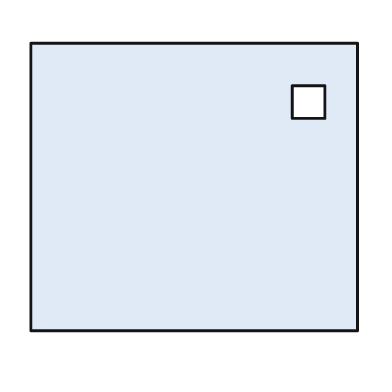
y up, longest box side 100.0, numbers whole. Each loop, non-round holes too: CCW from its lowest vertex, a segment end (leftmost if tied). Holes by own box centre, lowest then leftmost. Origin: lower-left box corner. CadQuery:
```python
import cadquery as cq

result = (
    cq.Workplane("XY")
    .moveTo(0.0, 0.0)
    .lineTo(100.0, 0.0)
    .lineTo(100.0, 88.0)
    .lineTo(0.0, 88.0)
    .close()
    .moveTo(80.0, 65.0)
    .lineTo(90.0, 65.0)
    .lineTo(90.0, 75.0)
    .lineTo(80.0, 75.0)
    .close()
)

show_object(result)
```